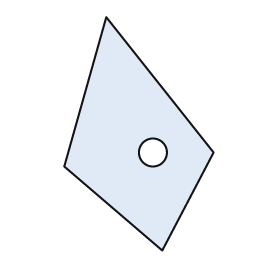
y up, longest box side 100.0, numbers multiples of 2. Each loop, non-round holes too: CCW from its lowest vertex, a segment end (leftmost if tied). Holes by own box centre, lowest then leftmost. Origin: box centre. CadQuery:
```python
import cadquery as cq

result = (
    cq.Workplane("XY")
    .moveTo(10.0, -50.0)
    .lineTo(32.0, -8.0)
    .lineTo(-14.0, 50.0)
    .lineTo(-32.0, -14.0)
    .close()
    .moveTo(6.0, -8.0)
    .circle(6.0)
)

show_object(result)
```